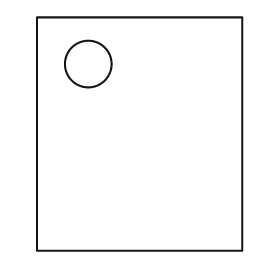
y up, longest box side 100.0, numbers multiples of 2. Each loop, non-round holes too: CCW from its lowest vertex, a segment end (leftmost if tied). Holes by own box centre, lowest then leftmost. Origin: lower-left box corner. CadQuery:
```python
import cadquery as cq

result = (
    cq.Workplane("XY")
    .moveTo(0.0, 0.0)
    .lineTo(88.0, 0.0)
    .lineTo(88.0, 100.0)
    .lineTo(0.0, 100.0)
    .close()
    .moveTo(22.0, 80.0)
    .circle(10.0)
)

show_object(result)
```